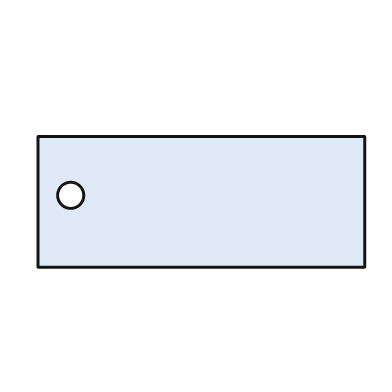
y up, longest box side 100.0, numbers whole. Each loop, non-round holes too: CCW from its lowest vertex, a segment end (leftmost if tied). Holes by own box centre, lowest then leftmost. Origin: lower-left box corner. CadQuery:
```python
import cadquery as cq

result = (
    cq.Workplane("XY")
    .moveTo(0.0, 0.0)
    .lineTo(100.0, 0.0)
    .lineTo(100.0, 40.0)
    .lineTo(0.0, 40.0)
    .close()
    .moveTo(10.0, 22.0)
    .circle(4.0)
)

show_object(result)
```